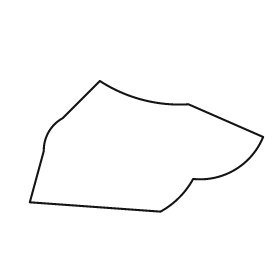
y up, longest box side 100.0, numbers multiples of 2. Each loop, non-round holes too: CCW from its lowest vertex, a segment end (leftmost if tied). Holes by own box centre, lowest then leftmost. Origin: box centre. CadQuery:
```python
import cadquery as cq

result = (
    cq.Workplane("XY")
    .moveTo(6.0, -28.0)
    .threePointArc((14.0, -22.0), (20.0, -14.0))
    .threePointArc((38.0, -10.0), (50.0, 4.0))
    .lineTo(18.0, 18.0)
    .threePointArc((-2.0, 20.0), (-20.0, 28.0))
    .lineTo(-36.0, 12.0)
    .threePointArc((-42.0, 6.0), (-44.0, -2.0))
    .lineTo(-50.0, -24.0)
    .close()
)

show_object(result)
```